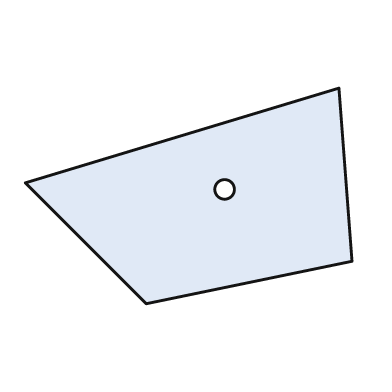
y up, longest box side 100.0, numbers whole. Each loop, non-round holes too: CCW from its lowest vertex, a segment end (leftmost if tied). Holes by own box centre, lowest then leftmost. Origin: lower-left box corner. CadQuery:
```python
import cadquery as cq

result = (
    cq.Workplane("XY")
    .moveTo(37.0, 0.0)
    .lineTo(100.0, 13.0)
    .lineTo(96.0, 66.0)
    .lineTo(0.0, 37.0)
    .close()
    .moveTo(61.0, 35.0)
    .circle(3.0)
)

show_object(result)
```